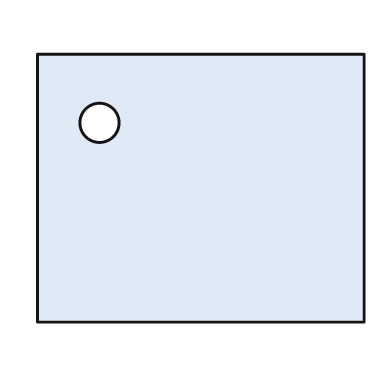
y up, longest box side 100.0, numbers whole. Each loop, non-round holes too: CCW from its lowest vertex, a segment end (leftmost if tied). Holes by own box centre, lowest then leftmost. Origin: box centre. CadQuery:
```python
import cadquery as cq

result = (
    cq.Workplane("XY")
    .moveTo(-50.0, -41.0)
    .lineTo(50.0, -41.0)
    .lineTo(50.0, 41.0)
    .lineTo(-50.0, 41.0)
    .close()
    .moveTo(-31.0, 20.0)
    .circle(6.0)
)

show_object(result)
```